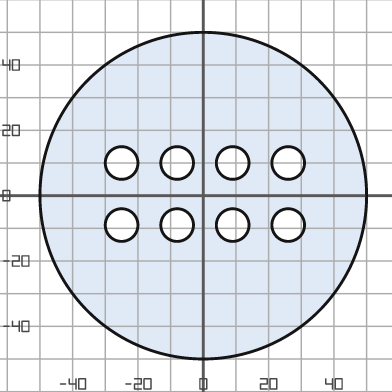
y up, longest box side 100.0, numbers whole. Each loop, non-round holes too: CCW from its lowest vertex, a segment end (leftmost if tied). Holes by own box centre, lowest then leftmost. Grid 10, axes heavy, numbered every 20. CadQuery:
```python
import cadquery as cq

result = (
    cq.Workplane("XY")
    .moveTo(0.0, 0.0)
    .circle(50.0)
    .moveTo(-25.0, -9.0)
    .circle(5.0)
    .moveTo(-8.0, -9.0)
    .circle(5.0)
    .moveTo(9.0, -9.0)
    .circle(5.0)
    .moveTo(26.0, -9.0)
    .circle(5.0)
    .moveTo(-25.0, 10.0)
    .circle(5.0)
    .moveTo(-8.0, 10.0)
    .circle(5.0)
    .moveTo(9.0, 10.0)
    .circle(5.0)
    .moveTo(26.0, 10.0)
    .circle(5.0)
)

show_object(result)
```